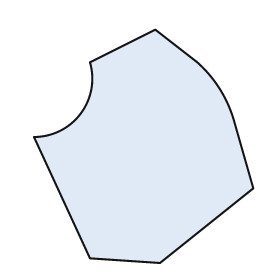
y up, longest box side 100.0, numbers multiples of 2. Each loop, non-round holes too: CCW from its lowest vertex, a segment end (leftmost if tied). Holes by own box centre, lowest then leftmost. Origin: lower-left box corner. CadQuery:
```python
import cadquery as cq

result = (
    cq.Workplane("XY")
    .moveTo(54.0, 0.0)
    .lineTo(94.0, 32.0)
    .lineTo(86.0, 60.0)
    .threePointArc((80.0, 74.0), (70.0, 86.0))
    .lineTo(52.0, 100.0)
    .lineTo(24.0, 86.0)
    .threePointArc((20.0, 64.0), (0.0, 54.0))
    .lineTo(24.0, 2.0)
    .close()
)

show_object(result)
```